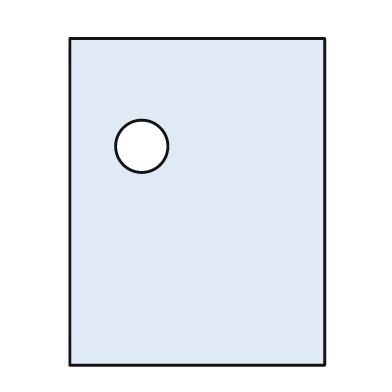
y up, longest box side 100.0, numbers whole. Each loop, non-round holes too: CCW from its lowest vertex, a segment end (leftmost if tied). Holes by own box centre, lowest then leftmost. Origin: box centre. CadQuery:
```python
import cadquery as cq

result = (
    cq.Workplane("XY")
    .moveTo(-39.0, -50.0)
    .lineTo(39.0, -50.0)
    .lineTo(39.0, 50.0)
    .lineTo(-39.0, 50.0)
    .close()
    .moveTo(-17.0, 17.0)
    .circle(8.0)
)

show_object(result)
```